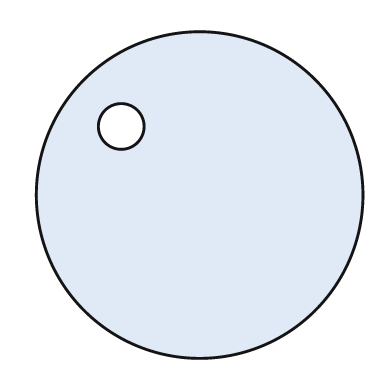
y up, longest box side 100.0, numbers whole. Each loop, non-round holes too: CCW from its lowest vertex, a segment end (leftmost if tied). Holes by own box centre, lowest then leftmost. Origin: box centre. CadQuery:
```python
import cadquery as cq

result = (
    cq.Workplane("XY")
    .moveTo(0.0, 0.0)
    .circle(50.0)
    .moveTo(-24.0, 21.0)
    .circle(7.0)
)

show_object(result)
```